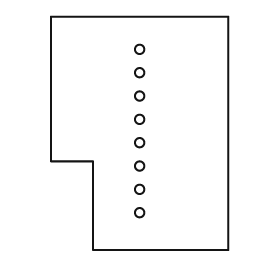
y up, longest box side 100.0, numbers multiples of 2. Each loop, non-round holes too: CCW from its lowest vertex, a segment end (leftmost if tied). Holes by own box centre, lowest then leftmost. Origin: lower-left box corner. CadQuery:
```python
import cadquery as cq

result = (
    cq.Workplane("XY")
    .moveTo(18.0, 0.0)
    .lineTo(76.0, 0.0)
    .lineTo(76.0, 100.0)
    .lineTo(0.0, 100.0)
    .lineTo(0.0, 38.0)
    .lineTo(18.0, 38.0)
    .close()
    .moveTo(38.0, 16.0)
    .circle(2.0)
    .moveTo(38.0, 26.0)
    .circle(2.0)
    .moveTo(38.0, 36.0)
    .circle(2.0)
    .moveTo(38.0, 46.0)
    .circle(2.0)
    .moveTo(38.0, 56.0)
    .circle(2.0)
    .moveTo(38.0, 66.0)
    .circle(2.0)
    .moveTo(38.0, 76.0)
    .circle(2.0)
    .moveTo(38.0, 86.0)
    .circle(2.0)
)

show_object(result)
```